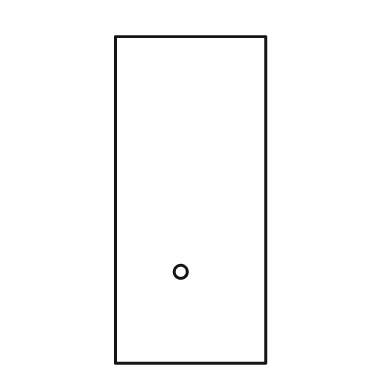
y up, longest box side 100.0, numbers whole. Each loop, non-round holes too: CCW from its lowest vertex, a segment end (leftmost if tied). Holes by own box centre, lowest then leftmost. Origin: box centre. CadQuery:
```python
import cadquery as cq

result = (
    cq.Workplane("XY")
    .moveTo(-23.0, -50.0)
    .lineTo(23.0, -50.0)
    .lineTo(23.0, 50.0)
    .lineTo(-23.0, 50.0)
    .close()
    .moveTo(-3.0, -22.0)
    .circle(2.0)
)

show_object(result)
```